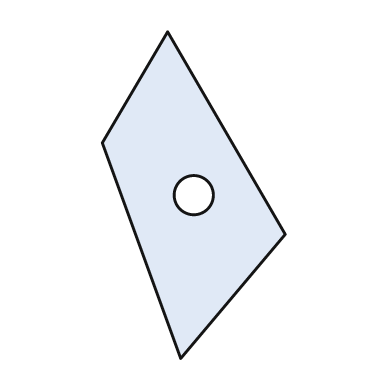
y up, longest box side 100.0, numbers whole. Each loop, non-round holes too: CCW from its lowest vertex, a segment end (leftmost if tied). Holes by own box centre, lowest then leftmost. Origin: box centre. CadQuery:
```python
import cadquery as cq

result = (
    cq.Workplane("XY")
    .moveTo(-4.0, -50.0)
    .lineTo(28.0, -12.0)
    .lineTo(-8.0, 50.0)
    .lineTo(-28.0, 16.0)
    .close()
    .moveTo(0.0, 0.0)
    .circle(6.0)
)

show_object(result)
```